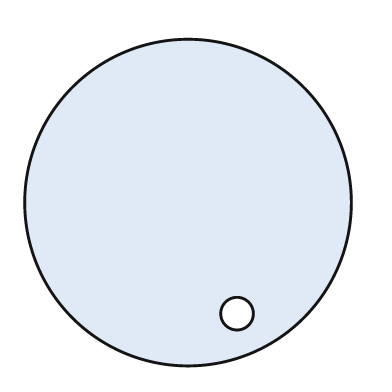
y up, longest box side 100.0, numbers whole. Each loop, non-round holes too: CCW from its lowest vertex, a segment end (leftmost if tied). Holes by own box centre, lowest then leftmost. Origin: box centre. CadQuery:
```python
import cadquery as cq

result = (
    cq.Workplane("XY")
    .moveTo(0.0, 0.0)
    .circle(50.0)
    .moveTo(15.0, -34.0)
    .circle(5.0)
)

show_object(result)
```